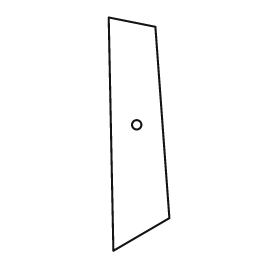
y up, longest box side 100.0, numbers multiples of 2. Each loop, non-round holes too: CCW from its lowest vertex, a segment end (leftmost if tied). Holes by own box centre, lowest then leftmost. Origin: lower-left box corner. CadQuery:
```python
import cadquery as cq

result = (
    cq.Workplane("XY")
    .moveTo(2.0, 0.0)
    .lineTo(26.0, 14.0)
    .lineTo(20.0, 96.0)
    .lineTo(0.0, 100.0)
    .close()
    .moveTo(12.0, 54.0)
    .circle(2.0)
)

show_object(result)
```